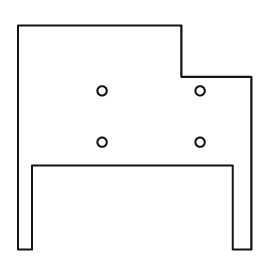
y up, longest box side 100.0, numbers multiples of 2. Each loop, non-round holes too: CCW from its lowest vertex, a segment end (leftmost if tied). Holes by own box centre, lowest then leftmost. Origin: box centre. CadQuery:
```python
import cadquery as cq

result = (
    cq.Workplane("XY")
    .moveTo(-50.0, -48.0)
    .lineTo(-44.0, -48.0)
    .lineTo(-44.0, -12.0)
    .lineTo(42.0, -12.0)
    .lineTo(42.0, -48.0)
    .lineTo(50.0, -48.0)
    .lineTo(50.0, 26.0)
    .lineTo(20.0, 26.0)
    .lineTo(20.0, 48.0)
    .lineTo(-50.0, 48.0)
    .close()
    .moveTo(-14.0, -2.0)
    .circle(2.0)
    .moveTo(28.0, -2.0)
    .circle(2.0)
    .moveTo(-14.0, 20.0)
    .circle(2.0)
    .moveTo(28.0, 20.0)
    .circle(2.0)
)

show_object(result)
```